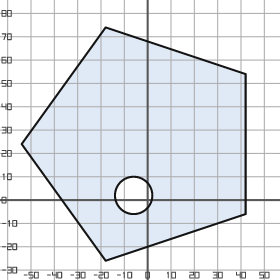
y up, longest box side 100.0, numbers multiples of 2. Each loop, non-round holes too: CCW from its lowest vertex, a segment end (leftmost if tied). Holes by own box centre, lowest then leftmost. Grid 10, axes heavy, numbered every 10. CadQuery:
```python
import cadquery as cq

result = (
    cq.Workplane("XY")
    .moveTo(-18.0, -26.0)
    .lineTo(42.0, -6.0)
    .lineTo(42.0, 54.0)
    .lineTo(-18.0, 74.0)
    .lineTo(-54.0, 24.0)
    .close()
    .moveTo(-6.0, 2.0)
    .circle(8.0)
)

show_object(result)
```